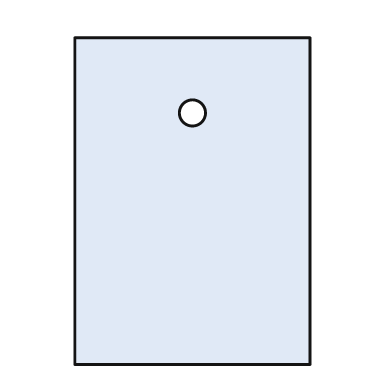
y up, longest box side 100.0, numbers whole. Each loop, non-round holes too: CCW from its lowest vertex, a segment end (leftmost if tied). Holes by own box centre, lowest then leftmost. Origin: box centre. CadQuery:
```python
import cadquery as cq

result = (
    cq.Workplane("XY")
    .moveTo(-36.0, -50.0)
    .lineTo(36.0, -50.0)
    .lineTo(36.0, 50.0)
    .lineTo(-36.0, 50.0)
    .close()
    .moveTo(0.0, 27.0)
    .circle(4.0)
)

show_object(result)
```